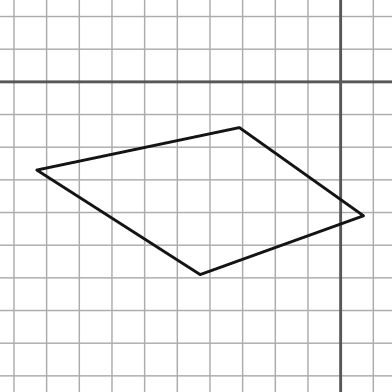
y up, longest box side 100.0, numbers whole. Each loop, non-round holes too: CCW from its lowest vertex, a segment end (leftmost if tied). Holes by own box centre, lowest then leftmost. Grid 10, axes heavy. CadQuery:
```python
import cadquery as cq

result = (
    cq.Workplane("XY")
    .moveTo(-43.0, -59.0)
    .lineTo(7.0, -41.0)
    .lineTo(-31.0, -14.0)
    .lineTo(-93.0, -27.0)
    .close()
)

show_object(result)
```